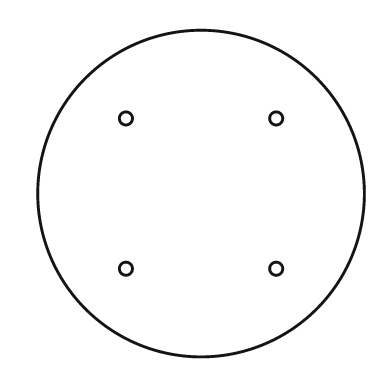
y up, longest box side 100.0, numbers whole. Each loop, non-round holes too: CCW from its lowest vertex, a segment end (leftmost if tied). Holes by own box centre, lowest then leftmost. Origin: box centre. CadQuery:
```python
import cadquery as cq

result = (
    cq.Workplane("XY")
    .moveTo(0.0, 0.0)
    .circle(50.0)
    .moveTo(-23.0, -23.0)
    .circle(2.0)
    .moveTo(23.0, -23.0)
    .circle(2.0)
    .moveTo(-23.0, 23.0)
    .circle(2.0)
    .moveTo(23.0, 23.0)
    .circle(2.0)
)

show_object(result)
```